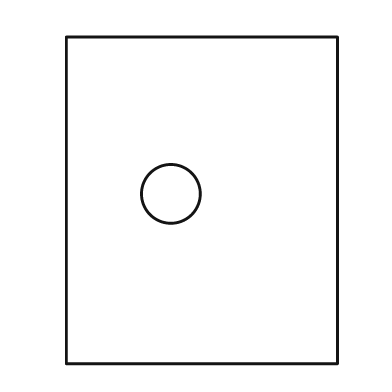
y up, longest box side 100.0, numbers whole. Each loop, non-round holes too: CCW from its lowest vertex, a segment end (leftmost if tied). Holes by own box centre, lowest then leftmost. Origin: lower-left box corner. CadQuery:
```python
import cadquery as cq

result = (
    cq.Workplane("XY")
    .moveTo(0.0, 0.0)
    .lineTo(83.0, 0.0)
    .lineTo(83.0, 100.0)
    .lineTo(0.0, 100.0)
    .close()
    .moveTo(32.0, 52.0)
    .circle(9.0)
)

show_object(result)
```